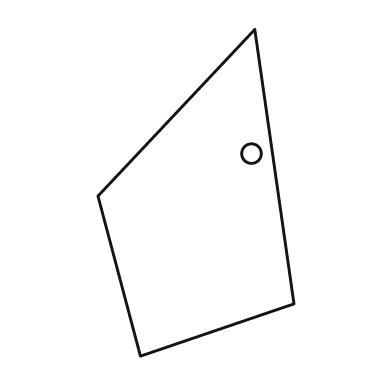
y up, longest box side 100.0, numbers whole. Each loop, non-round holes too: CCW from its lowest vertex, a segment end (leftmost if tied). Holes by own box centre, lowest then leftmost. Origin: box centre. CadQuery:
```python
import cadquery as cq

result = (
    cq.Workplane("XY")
    .moveTo(-17.0, -50.0)
    .lineTo(30.0, -34.0)
    .lineTo(18.0, 50.0)
    .lineTo(-30.0, -1.0)
    .close()
    .moveTo(17.0, 12.0)
    .circle(3.0)
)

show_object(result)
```